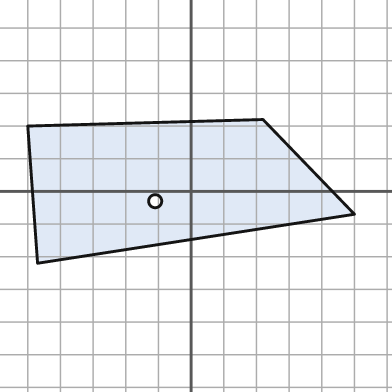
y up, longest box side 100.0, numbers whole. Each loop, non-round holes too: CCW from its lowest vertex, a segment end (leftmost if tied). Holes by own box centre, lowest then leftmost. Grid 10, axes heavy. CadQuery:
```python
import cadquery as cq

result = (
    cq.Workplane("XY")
    .moveTo(-47.0, -22.0)
    .lineTo(50.0, -7.0)
    .lineTo(22.0, 22.0)
    .lineTo(-50.0, 20.0)
    .close()
    .moveTo(-11.0, -3.0)
    .circle(2.0)
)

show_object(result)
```